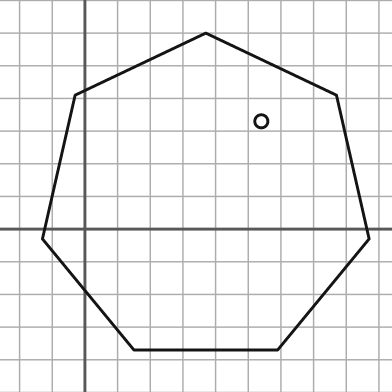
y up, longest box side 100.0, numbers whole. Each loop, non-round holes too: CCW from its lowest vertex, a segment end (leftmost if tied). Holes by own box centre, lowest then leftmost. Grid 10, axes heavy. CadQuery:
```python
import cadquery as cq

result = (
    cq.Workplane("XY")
    .moveTo(15.0, -37.0)
    .lineTo(59.0, -37.0)
    .lineTo(87.0, -3.0)
    .lineTo(77.0, 41.0)
    .lineTo(37.0, 60.0)
    .lineTo(-3.0, 41.0)
    .lineTo(-13.0, -3.0)
    .close()
    .moveTo(54.0, 33.0)
    .circle(2.0)
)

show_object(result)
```